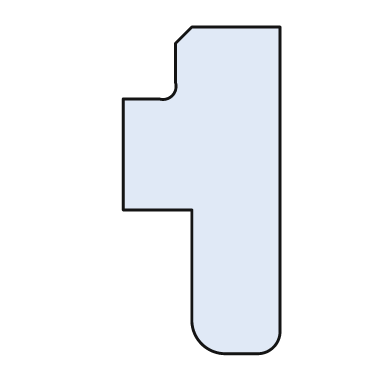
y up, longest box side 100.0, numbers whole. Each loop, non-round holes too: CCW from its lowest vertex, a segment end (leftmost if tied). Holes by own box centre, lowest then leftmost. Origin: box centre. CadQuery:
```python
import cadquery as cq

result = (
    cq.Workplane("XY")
    .moveTo(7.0, -50.0)
    .lineTo(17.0, -50.0)
    .threePointArc((22.0, -48.0), (24.0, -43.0))
    .lineTo(24.0, 50.0)
    .lineTo(-3.0, 50.0)
    .lineTo(-8.0, 45.0)
    .lineTo(-8.0, 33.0)
    .threePointArc((-9.0, 29.0), (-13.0, 28.0))
    .lineTo(-24.0, 28.0)
    .lineTo(-24.0, -6.0)
    .lineTo(-3.0, -6.0)
    .lineTo(-3.0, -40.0)
    .threePointArc((0.0, -47.0), (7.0, -50.0))
    .close()
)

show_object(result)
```